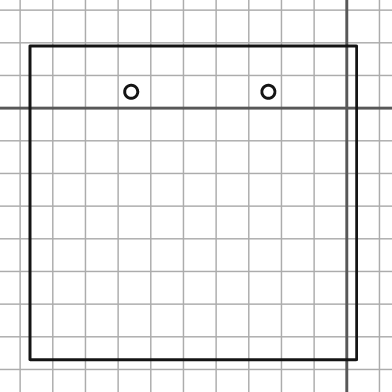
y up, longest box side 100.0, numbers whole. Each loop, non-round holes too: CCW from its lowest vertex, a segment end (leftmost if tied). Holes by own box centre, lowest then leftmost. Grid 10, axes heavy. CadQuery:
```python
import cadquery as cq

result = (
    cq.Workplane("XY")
    .moveTo(-97.0, -77.0)
    .lineTo(3.0, -77.0)
    .lineTo(3.0, 19.0)
    .lineTo(-97.0, 19.0)
    .close()
    .moveTo(-66.0, 5.0)
    .circle(2.0)
    .moveTo(-24.0, 5.0)
    .circle(2.0)
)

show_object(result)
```